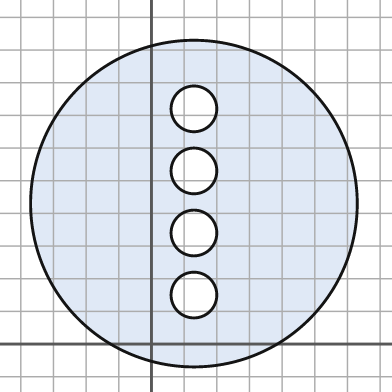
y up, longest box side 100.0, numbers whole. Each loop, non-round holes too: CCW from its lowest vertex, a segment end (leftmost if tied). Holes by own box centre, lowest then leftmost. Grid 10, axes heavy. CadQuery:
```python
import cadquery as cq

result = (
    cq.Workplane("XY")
    .moveTo(13.0, 43.0)
    .circle(50.0)
    .moveTo(13.0, 15.0)
    .circle(7.0)
    .moveTo(13.0, 34.0)
    .circle(7.0)
    .moveTo(13.0, 53.0)
    .circle(7.0)
    .moveTo(13.0, 72.0)
    .circle(7.0)
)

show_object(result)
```